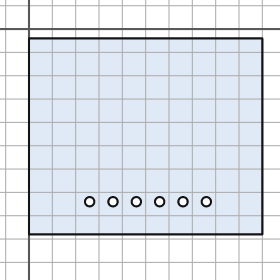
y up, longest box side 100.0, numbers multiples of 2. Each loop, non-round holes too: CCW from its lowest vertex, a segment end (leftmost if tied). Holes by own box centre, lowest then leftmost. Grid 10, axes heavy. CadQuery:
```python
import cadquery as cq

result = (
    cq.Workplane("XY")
    .moveTo(0.0, -88.0)
    .lineTo(100.0, -88.0)
    .lineTo(100.0, -4.0)
    .lineTo(0.0, -4.0)
    .close()
    .moveTo(26.0, -74.0)
    .circle(2.0)
    .moveTo(36.0, -74.0)
    .circle(2.0)
    .moveTo(46.0, -74.0)
    .circle(2.0)
    .moveTo(56.0, -74.0)
    .circle(2.0)
    .moveTo(66.0, -74.0)
    .circle(2.0)
    .moveTo(76.0, -74.0)
    .circle(2.0)
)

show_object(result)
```